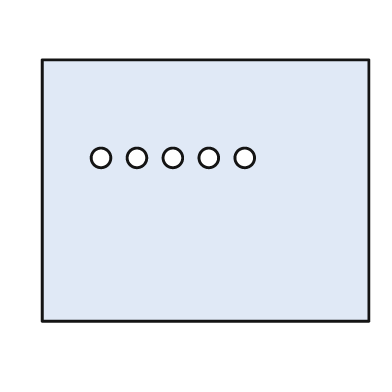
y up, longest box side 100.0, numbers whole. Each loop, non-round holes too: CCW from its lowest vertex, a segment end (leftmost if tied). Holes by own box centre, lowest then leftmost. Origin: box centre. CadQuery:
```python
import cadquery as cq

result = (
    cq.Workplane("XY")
    .moveTo(-50.0, -40.0)
    .lineTo(50.0, -40.0)
    .lineTo(50.0, 40.0)
    .lineTo(-50.0, 40.0)
    .close()
    .moveTo(-32.0, 10.0)
    .circle(3.0)
    .moveTo(-21.0, 10.0)
    .circle(3.0)
    .moveTo(-10.0, 10.0)
    .circle(3.0)
    .moveTo(1.0, 10.0)
    .circle(3.0)
    .moveTo(12.0, 10.0)
    .circle(3.0)
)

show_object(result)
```